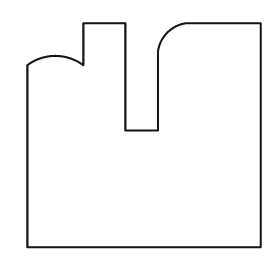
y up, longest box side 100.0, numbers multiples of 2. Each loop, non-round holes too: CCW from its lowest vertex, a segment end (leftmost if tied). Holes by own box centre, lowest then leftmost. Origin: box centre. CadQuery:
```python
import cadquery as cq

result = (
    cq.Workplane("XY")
    .moveTo(-50.0, -48.0)
    .lineTo(50.0, -48.0)
    .lineTo(50.0, 48.0)
    .lineTo(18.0, 48.0)
    .threePointArc((10.0, 44.0), (6.0, 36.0))
    .lineTo(6.0, 2.0)
    .lineTo(-8.0, 2.0)
    .lineTo(-8.0, 48.0)
    .lineTo(-26.0, 48.0)
    .lineTo(-26.0, 30.0)
    .threePointArc((-38.0, 34.0), (-50.0, 30.0))
    .close()
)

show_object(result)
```